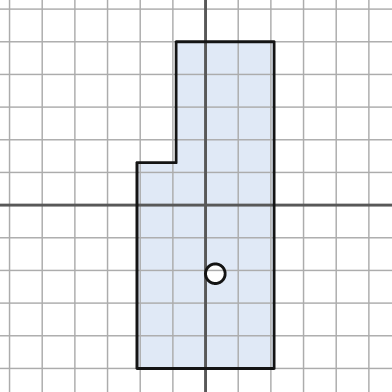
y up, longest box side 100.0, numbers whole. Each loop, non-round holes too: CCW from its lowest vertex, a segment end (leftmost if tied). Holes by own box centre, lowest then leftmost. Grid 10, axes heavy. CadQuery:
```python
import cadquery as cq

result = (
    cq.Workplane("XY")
    .moveTo(-21.0, -50.0)
    .lineTo(21.0, -50.0)
    .lineTo(21.0, 50.0)
    .lineTo(-9.0, 50.0)
    .lineTo(-9.0, 13.0)
    .lineTo(-21.0, 13.0)
    .close()
    .moveTo(3.0, -21.0)
    .circle(3.0)
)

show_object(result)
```